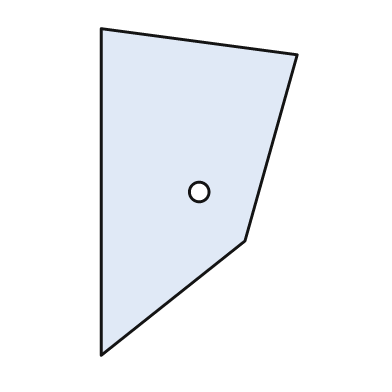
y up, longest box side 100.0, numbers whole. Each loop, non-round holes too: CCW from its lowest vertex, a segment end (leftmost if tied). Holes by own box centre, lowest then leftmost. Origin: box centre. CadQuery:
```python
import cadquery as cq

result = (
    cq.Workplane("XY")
    .moveTo(-30.0, -50.0)
    .lineTo(14.0, -15.0)
    .lineTo(30.0, 42.0)
    .lineTo(-30.0, 50.0)
    .close()
    .moveTo(0.0, 0.0)
    .circle(3.0)
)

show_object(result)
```